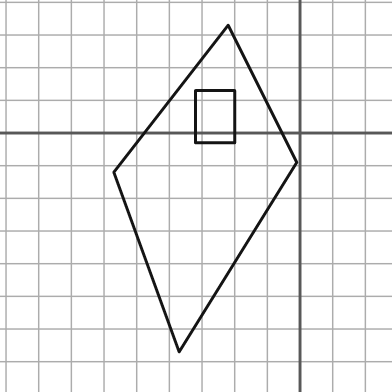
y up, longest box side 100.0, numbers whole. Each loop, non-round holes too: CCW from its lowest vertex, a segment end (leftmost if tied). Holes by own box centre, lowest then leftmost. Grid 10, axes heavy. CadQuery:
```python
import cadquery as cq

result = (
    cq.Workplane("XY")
    .moveTo(-37.0, -67.0)
    .lineTo(-1.0, -9.0)
    .lineTo(-22.0, 33.0)
    .lineTo(-57.0, -12.0)
    .close()
    .moveTo(-32.0, -3.0)
    .lineTo(-20.0, -3.0)
    .lineTo(-20.0, 13.0)
    .lineTo(-32.0, 13.0)
    .close()
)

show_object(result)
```